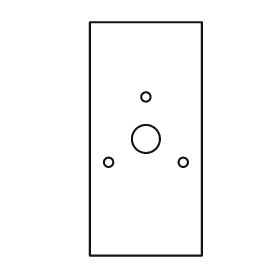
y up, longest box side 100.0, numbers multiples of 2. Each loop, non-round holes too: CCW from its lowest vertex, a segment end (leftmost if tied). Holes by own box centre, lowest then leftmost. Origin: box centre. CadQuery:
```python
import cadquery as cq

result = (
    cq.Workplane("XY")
    .moveTo(-24.0, -50.0)
    .lineTo(24.0, -50.0)
    .lineTo(24.0, 50.0)
    .lineTo(-24.0, 50.0)
    .close()
    .moveTo(-16.0, -10.0)
    .circle(2.0)
    .moveTo(16.0, -10.0)
    .circle(2.0)
    .moveTo(0.0, 0.0)
    .circle(6.0)
    .moveTo(0.0, 18.0)
    .circle(2.0)
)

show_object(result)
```